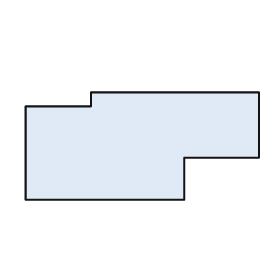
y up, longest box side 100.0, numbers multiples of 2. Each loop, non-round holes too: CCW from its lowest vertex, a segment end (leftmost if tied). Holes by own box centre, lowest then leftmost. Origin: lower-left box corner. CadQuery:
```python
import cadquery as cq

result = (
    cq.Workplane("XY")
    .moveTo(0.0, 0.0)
    .lineTo(68.0, 0.0)
    .lineTo(68.0, 18.0)
    .lineTo(100.0, 18.0)
    .lineTo(100.0, 46.0)
    .lineTo(28.0, 46.0)
    .lineTo(28.0, 40.0)
    .lineTo(0.0, 40.0)
    .close()
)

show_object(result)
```